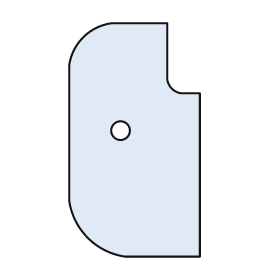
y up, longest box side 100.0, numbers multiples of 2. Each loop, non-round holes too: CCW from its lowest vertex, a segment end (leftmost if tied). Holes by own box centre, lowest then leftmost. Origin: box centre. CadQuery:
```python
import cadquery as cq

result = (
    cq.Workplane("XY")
    .moveTo(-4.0, -50.0)
    .lineTo(28.0, -50.0)
    .lineTo(28.0, 20.0)
    .lineTo(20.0, 20.0)
    .threePointArc((16.0, 22.0), (14.0, 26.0))
    .lineTo(14.0, 50.0)
    .lineTo(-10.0, 50.0)
    .threePointArc((-22.0, 44.0), (-28.0, 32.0))
    .lineTo(-28.0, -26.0)
    .threePointArc((-20.0, -42.0), (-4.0, -50.0))
    .close()
    .moveTo(-6.0, 4.0)
    .circle(4.0)
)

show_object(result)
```